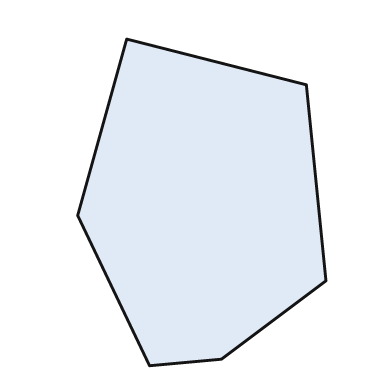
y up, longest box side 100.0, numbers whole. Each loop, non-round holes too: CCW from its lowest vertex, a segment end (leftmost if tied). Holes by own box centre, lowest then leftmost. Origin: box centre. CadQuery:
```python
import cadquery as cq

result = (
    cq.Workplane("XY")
    .moveTo(-16.0, -50.0)
    .lineTo(6.0, -48.0)
    .lineTo(38.0, -24.0)
    .lineTo(32.0, 36.0)
    .lineTo(-23.0, 50.0)
    .lineTo(-38.0, -4.0)
    .close()
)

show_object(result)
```